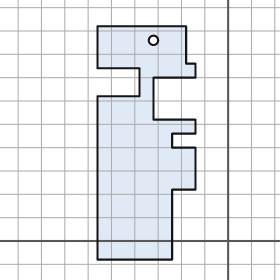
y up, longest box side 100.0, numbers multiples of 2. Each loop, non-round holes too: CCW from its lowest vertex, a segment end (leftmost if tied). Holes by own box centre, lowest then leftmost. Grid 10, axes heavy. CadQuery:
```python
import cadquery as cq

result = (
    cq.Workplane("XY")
    .moveTo(-56.0, -8.0)
    .lineTo(-24.0, -8.0)
    .lineTo(-24.0, 22.0)
    .lineTo(-14.0, 22.0)
    .lineTo(-14.0, 40.0)
    .lineTo(-24.0, 40.0)
    .lineTo(-24.0, 46.0)
    .lineTo(-14.0, 46.0)
    .lineTo(-14.0, 52.0)
    .lineTo(-32.0, 52.0)
    .lineTo(-32.0, 70.0)
    .lineTo(-14.0, 70.0)
    .lineTo(-14.0, 76.0)
    .lineTo(-18.0, 76.0)
    .lineTo(-18.0, 92.0)
    .lineTo(-56.0, 92.0)
    .lineTo(-56.0, 74.0)
    .lineTo(-38.0, 74.0)
    .lineTo(-38.0, 62.0)
    .lineTo(-56.0, 62.0)
    .close()
    .moveTo(-32.0, 86.0)
    .circle(2.0)
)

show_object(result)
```